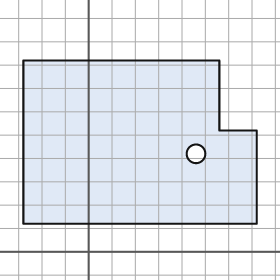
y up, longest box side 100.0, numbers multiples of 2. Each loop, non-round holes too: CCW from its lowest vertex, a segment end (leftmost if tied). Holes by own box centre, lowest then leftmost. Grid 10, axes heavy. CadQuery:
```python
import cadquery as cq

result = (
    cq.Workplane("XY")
    .moveTo(-28.0, 12.0)
    .lineTo(72.0, 12.0)
    .lineTo(72.0, 52.0)
    .lineTo(56.0, 52.0)
    .lineTo(56.0, 82.0)
    .lineTo(-28.0, 82.0)
    .close()
    .moveTo(46.0, 42.0)
    .circle(4.0)
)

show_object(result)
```